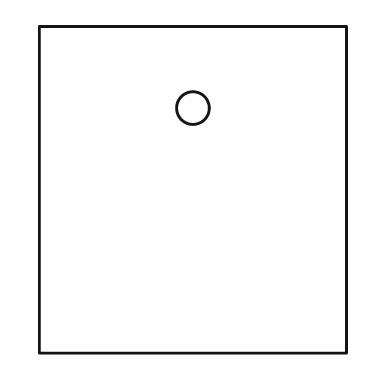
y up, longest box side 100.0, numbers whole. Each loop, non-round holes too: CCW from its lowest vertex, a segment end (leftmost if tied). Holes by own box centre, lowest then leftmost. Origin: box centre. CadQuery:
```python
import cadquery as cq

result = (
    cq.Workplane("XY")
    .moveTo(-47.0, -50.0)
    .lineTo(47.0, -50.0)
    .lineTo(47.0, 50.0)
    .lineTo(-47.0, 50.0)
    .close()
    .moveTo(0.0, 25.0)
    .circle(5.0)
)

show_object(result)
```